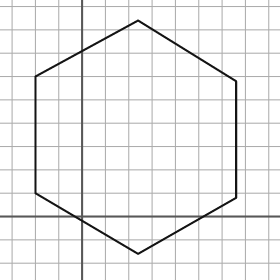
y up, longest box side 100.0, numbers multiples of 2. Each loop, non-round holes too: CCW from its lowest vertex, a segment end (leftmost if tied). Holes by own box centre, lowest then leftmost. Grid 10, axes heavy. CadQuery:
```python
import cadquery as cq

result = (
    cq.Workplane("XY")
    .moveTo(24.0, -16.0)
    .lineTo(66.0, 8.0)
    .lineTo(66.0, 58.0)
    .lineTo(24.0, 84.0)
    .lineTo(-20.0, 60.0)
    .lineTo(-20.0, 10.0)
    .close()
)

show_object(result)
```